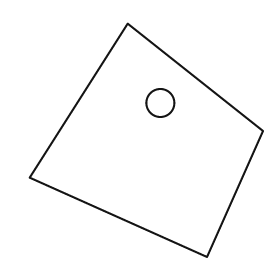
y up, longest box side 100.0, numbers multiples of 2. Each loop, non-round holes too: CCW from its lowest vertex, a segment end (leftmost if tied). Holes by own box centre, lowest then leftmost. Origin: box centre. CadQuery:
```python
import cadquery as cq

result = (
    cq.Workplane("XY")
    .moveTo(26.0, -50.0)
    .lineTo(50.0, 4.0)
    .lineTo(-8.0, 50.0)
    .lineTo(-50.0, -16.0)
    .close()
    .moveTo(6.0, 16.0)
    .circle(6.0)
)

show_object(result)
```